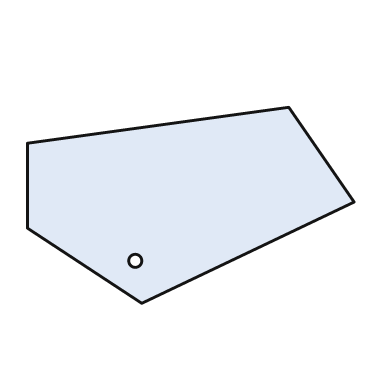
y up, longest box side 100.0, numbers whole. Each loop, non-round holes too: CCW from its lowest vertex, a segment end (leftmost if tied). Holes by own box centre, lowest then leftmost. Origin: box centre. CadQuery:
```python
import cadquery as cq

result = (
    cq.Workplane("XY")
    .moveTo(-15.0, -30.0)
    .lineTo(50.0, 1.0)
    .lineTo(30.0, 30.0)
    .lineTo(-50.0, 19.0)
    .lineTo(-50.0, -7.0)
    .close()
    .moveTo(-17.0, -17.0)
    .circle(2.0)
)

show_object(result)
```